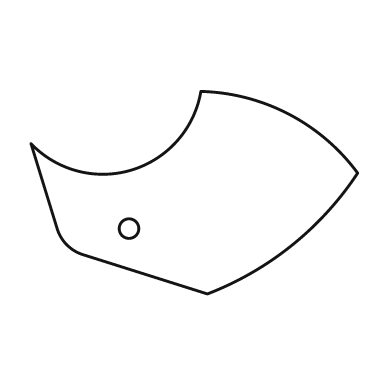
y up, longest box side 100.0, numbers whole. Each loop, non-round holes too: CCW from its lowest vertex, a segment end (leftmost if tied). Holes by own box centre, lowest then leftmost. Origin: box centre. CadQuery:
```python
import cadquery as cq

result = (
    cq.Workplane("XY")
    .moveTo(4.0, -31.0)
    .threePointArc((30.0, -16.0), (50.0, 6.0))
    .threePointArc((29.0, 24.0), (2.0, 31.0))
    .threePointArc((-19.0, 7.0), (-50.0, 15.0))
    .lineTo(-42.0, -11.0)
    .threePointArc((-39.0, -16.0), (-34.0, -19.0))
    .close()
    .moveTo(-20.0, -11.0)
    .circle(3.0)
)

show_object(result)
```